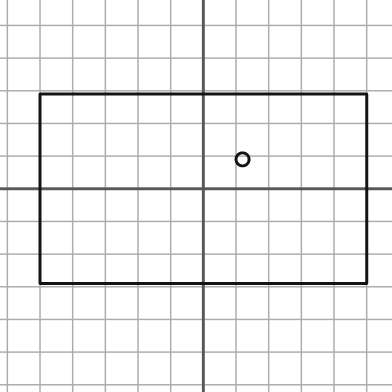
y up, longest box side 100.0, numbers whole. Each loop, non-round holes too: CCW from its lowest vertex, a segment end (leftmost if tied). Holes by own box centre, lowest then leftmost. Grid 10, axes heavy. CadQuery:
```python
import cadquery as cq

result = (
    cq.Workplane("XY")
    .moveTo(-50.0, -29.0)
    .lineTo(50.0, -29.0)
    .lineTo(50.0, 29.0)
    .lineTo(-50.0, 29.0)
    .close()
    .moveTo(12.0, 9.0)
    .circle(2.0)
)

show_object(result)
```